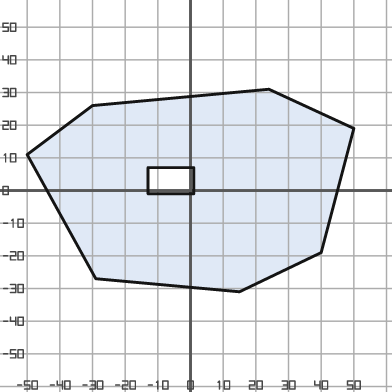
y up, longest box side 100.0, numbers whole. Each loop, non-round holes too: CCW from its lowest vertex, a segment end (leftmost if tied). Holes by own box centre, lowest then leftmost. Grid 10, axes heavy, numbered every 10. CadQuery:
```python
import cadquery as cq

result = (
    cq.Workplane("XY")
    .moveTo(15.0, -31.0)
    .lineTo(40.0, -19.0)
    .lineTo(50.0, 19.0)
    .lineTo(24.0, 31.0)
    .lineTo(-30.0, 26.0)
    .lineTo(-50.0, 11.0)
    .lineTo(-29.0, -27.0)
    .close()
    .moveTo(-13.0, -1.0)
    .lineTo(1.0, -1.0)
    .lineTo(1.0, 7.0)
    .lineTo(-13.0, 7.0)
    .close()
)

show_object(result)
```